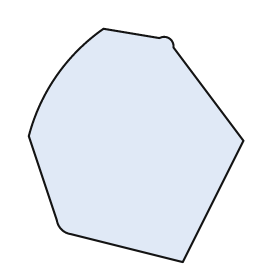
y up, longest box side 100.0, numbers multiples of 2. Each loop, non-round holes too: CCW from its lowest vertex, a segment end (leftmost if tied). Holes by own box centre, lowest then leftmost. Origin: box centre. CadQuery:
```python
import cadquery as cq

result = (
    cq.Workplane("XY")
    .moveTo(20.0, -50.0)
    .lineTo(46.0, 2.0)
    .lineTo(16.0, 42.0)
    .threePointArc((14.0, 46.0), (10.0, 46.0))
    .lineTo(-14.0, 50.0)
    .threePointArc((-34.0, 30.0), (-46.0, 4.0))
    .lineTo(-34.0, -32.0)
    .threePointArc((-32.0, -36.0), (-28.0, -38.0))
    .close()
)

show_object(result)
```